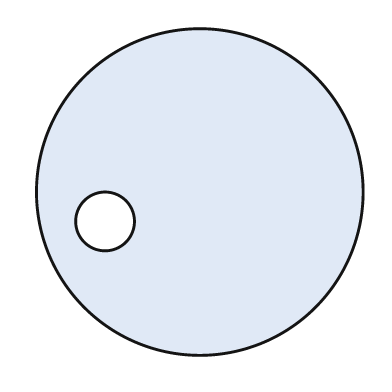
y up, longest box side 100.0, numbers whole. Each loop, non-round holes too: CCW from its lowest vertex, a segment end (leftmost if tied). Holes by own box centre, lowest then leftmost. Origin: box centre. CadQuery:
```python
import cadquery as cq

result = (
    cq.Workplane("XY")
    .moveTo(0.0, 0.0)
    .circle(50.0)
    .moveTo(-29.0, -9.0)
    .circle(9.0)
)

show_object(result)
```